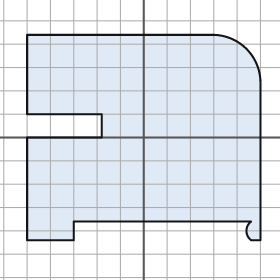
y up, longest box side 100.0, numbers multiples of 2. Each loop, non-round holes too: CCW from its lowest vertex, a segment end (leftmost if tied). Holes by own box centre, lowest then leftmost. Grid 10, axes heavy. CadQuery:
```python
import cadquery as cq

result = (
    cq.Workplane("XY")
    .moveTo(-50.0, -44.0)
    .lineTo(-30.0, -44.0)
    .lineTo(-30.0, -36.0)
    .lineTo(46.0, -36.0)
    .threePointArc((44.0, -40.0), (46.0, -44.0))
    .lineTo(50.0, -44.0)
    .lineTo(50.0, 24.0)
    .threePointArc((44.0, 38.0), (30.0, 44.0))
    .lineTo(-50.0, 44.0)
    .lineTo(-50.0, 10.0)
    .lineTo(-18.0, 10.0)
    .lineTo(-18.0, 0.0)
    .lineTo(-50.0, 0.0)
    .close()
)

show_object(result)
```